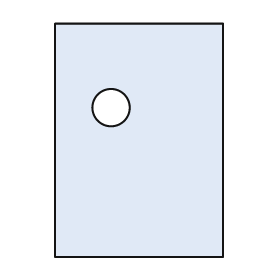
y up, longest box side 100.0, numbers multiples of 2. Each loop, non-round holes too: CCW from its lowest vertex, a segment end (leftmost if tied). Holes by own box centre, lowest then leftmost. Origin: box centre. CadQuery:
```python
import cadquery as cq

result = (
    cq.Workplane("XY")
    .moveTo(-36.0, -50.0)
    .lineTo(36.0, -50.0)
    .lineTo(36.0, 50.0)
    .lineTo(-36.0, 50.0)
    .close()
    .moveTo(-12.0, 14.0)
    .circle(8.0)
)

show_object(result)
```